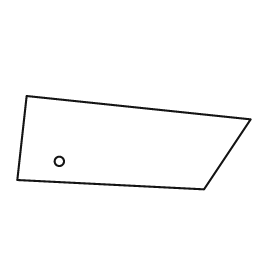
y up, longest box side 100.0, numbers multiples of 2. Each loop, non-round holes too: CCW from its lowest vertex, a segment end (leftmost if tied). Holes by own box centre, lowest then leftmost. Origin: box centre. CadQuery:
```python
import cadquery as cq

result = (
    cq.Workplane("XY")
    .moveTo(30.0, -20.0)
    .lineTo(50.0, 10.0)
    .lineTo(-46.0, 20.0)
    .lineTo(-50.0, -16.0)
    .close()
    .moveTo(-32.0, -8.0)
    .circle(2.0)
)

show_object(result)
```